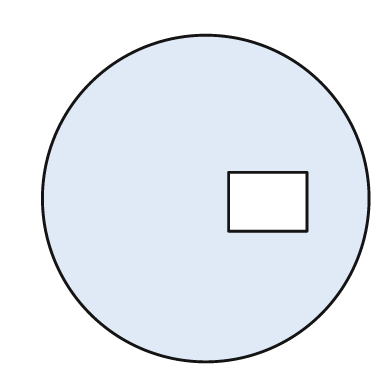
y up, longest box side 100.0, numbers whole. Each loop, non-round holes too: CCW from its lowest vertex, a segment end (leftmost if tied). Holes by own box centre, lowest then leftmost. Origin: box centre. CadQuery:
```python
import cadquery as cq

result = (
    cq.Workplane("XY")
    .moveTo(0.0, 0.0)
    .circle(50.0)
    .moveTo(7.0, -10.0)
    .lineTo(31.0, -10.0)
    .lineTo(31.0, 8.0)
    .lineTo(7.0, 8.0)
    .close()
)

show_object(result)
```